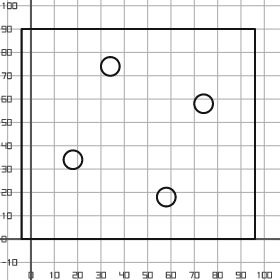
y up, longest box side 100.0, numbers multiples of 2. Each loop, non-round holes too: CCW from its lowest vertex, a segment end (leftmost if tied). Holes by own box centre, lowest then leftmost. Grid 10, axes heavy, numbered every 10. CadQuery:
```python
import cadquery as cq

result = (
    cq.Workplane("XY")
    .moveTo(-4.0, 0.0)
    .lineTo(96.0, 0.0)
    .lineTo(96.0, 90.0)
    .lineTo(-4.0, 90.0)
    .close()
    .moveTo(58.0, 18.0)
    .circle(4.0)
    .moveTo(18.0, 34.0)
    .circle(4.0)
    .moveTo(74.0, 58.0)
    .circle(4.0)
    .moveTo(34.0, 74.0)
    .circle(4.0)
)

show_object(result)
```